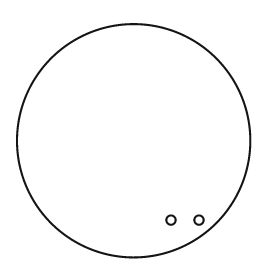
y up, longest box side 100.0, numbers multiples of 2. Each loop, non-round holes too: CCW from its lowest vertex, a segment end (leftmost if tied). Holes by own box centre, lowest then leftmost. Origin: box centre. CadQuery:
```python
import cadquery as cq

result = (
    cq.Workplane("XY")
    .moveTo(0.0, 0.0)
    .circle(50.0)
    .moveTo(16.0, -34.0)
    .circle(2.0)
    .moveTo(28.0, -34.0)
    .circle(2.0)
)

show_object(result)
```